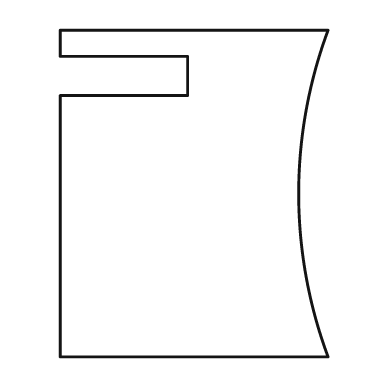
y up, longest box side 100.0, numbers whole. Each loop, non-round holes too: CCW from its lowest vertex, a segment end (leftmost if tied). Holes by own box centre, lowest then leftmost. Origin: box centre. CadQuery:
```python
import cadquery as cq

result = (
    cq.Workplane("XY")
    .moveTo(-41.0, -50.0)
    .lineTo(41.0, -50.0)
    .threePointArc((32.0, 0.0), (41.0, 50.0))
    .lineTo(-41.0, 50.0)
    .lineTo(-41.0, 42.0)
    .lineTo(-2.0, 42.0)
    .lineTo(-2.0, 30.0)
    .lineTo(-41.0, 30.0)
    .close()
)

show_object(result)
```